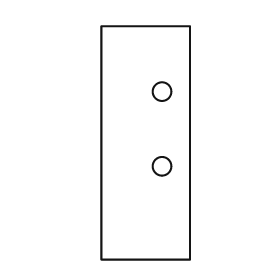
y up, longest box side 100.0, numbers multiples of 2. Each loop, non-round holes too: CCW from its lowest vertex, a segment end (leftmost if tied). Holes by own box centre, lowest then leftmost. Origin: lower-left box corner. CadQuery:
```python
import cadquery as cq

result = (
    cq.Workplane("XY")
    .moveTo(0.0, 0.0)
    .lineTo(38.0, 0.0)
    .lineTo(38.0, 100.0)
    .lineTo(0.0, 100.0)
    .close()
    .moveTo(26.0, 40.0)
    .circle(4.0)
    .moveTo(26.0, 72.0)
    .circle(4.0)
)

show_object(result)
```